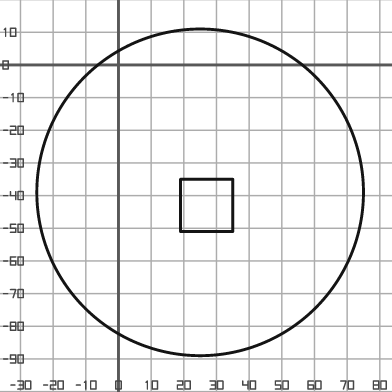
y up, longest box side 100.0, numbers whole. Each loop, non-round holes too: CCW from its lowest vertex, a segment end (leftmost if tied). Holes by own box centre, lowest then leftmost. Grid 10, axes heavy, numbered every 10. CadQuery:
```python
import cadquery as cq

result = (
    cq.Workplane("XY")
    .moveTo(25.0, -39.0)
    .circle(50.0)
    .moveTo(19.0, -51.0)
    .lineTo(35.0, -51.0)
    .lineTo(35.0, -35.0)
    .lineTo(19.0, -35.0)
    .close()
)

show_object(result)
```